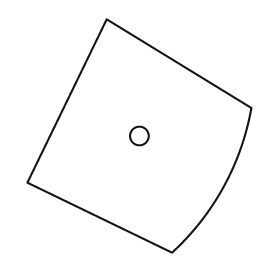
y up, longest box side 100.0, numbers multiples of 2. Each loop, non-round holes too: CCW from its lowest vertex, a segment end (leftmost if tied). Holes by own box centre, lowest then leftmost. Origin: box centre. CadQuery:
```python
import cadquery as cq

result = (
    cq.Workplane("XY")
    .moveTo(14.0, -50.0)
    .threePointArc((36.0, -22.0), (48.0, 12.0))
    .lineTo(-14.0, 50.0)
    .lineTo(-48.0, -20.0)
    .close()
    .moveTo(0.0, 0.0)
    .circle(4.0)
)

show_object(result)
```